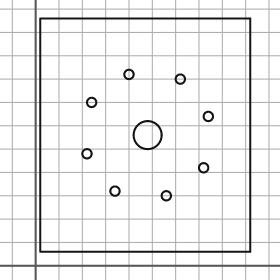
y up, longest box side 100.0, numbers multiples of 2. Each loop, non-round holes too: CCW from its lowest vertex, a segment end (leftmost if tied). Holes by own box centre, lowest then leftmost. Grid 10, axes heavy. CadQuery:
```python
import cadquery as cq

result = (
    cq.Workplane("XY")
    .moveTo(2.0, 6.0)
    .lineTo(92.0, 6.0)
    .lineTo(92.0, 106.0)
    .lineTo(2.0, 106.0)
    .close()
    .moveTo(56.0, 30.0)
    .circle(2.0)
    .moveTo(34.0, 32.0)
    .circle(2.0)
    .moveTo(72.0, 42.0)
    .circle(2.0)
    .moveTo(22.0, 48.0)
    .circle(2.0)
    .moveTo(48.0, 56.0)
    .circle(6.0)
    .moveTo(74.0, 64.0)
    .circle(2.0)
    .moveTo(24.0, 70.0)
    .circle(2.0)
    .moveTo(62.0, 80.0)
    .circle(2.0)
    .moveTo(40.0, 82.0)
    .circle(2.0)
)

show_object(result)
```